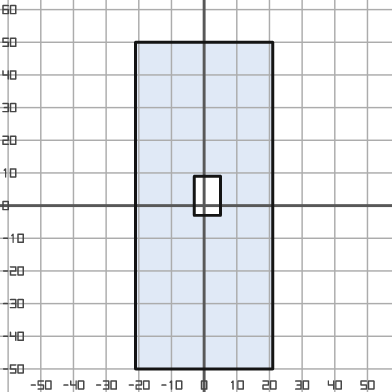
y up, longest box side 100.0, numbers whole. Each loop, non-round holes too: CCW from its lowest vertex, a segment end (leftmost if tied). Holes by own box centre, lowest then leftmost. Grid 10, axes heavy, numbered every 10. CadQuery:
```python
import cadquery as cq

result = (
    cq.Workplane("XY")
    .moveTo(-21.0, -50.0)
    .lineTo(21.0, -50.0)
    .lineTo(21.0, 50.0)
    .lineTo(-21.0, 50.0)
    .close()
    .moveTo(-3.0, -3.0)
    .lineTo(5.0, -3.0)
    .lineTo(5.0, 9.0)
    .lineTo(-3.0, 9.0)
    .close()
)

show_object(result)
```